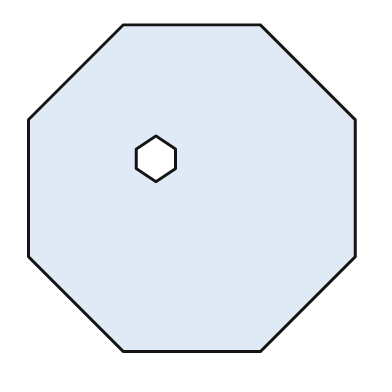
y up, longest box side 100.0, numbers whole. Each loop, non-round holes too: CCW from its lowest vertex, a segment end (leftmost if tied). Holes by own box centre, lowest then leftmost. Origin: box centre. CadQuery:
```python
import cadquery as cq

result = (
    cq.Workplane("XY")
    .moveTo(-21.0, -50.0)
    .lineTo(21.0, -50.0)
    .lineTo(50.0, -21.0)
    .lineTo(50.0, 21.0)
    .lineTo(21.0, 50.0)
    .lineTo(-21.0, 50.0)
    .lineTo(-50.0, 21.0)
    .lineTo(-50.0, -21.0)
    .close()
    .moveTo(-11.0, 2.0)
    .lineTo(-5.0, 6.0)
    .lineTo(-5.0, 12.0)
    .lineTo(-11.0, 16.0)
    .lineTo(-17.0, 12.0)
    .lineTo(-17.0, 6.0)
    .close()
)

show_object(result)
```